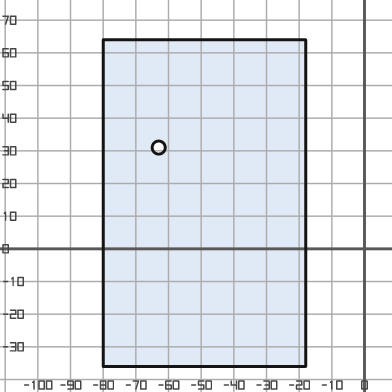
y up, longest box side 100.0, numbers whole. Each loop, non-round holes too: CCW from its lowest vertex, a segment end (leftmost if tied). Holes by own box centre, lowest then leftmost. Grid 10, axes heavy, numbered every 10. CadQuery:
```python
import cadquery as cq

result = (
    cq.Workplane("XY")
    .moveTo(-80.0, -36.0)
    .lineTo(-18.0, -36.0)
    .lineTo(-18.0, 64.0)
    .lineTo(-80.0, 64.0)
    .close()
    .moveTo(-63.0, 31.0)
    .circle(2.0)
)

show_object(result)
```